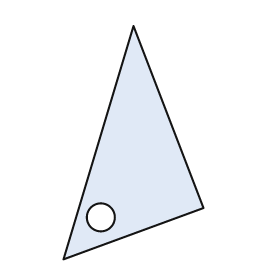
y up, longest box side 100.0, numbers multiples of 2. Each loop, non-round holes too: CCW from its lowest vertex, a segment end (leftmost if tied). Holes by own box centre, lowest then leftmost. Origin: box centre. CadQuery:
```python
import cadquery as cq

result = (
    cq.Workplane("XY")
    .moveTo(-30.0, -50.0)
    .lineTo(30.0, -28.0)
    .lineTo(0.0, 50.0)
    .close()
    .moveTo(-14.0, -32.0)
    .circle(6.0)
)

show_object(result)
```